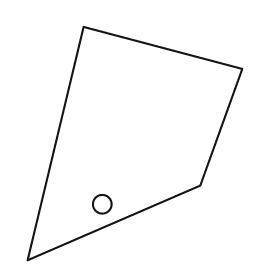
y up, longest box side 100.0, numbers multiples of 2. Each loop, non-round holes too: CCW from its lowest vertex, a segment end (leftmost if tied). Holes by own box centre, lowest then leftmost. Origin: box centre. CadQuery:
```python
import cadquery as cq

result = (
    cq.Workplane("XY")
    .moveTo(-46.0, -50.0)
    .lineTo(28.0, -18.0)
    .lineTo(46.0, 32.0)
    .lineTo(-22.0, 50.0)
    .close()
    .moveTo(-14.0, -26.0)
    .circle(4.0)
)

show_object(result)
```